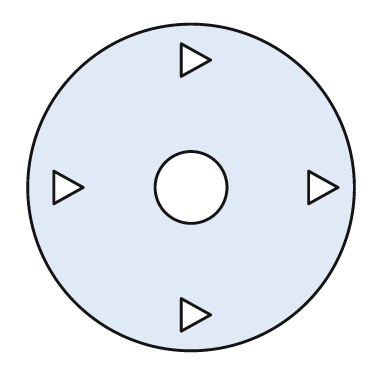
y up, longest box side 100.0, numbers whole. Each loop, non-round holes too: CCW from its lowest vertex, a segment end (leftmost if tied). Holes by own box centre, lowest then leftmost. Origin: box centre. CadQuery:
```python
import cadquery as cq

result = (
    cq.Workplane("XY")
    .moveTo(0.0, 0.0)
    .circle(50.0)
    .moveTo(-3.0, -44.0)
    .lineTo(6.0, -39.0)
    .lineTo(-3.0, -34.0)
    .close()
    .moveTo(-42.0, -5.0)
    .lineTo(-33.0, 0.0)
    .lineTo(-42.0, 5.0)
    .close()
    .moveTo(0.0, 0.0)
    .circle(11.0)
    .moveTo(36.0, -5.0)
    .lineTo(45.0, 0.0)
    .lineTo(36.0, 5.0)
    .close()
    .moveTo(-3.0, 34.0)
    .lineTo(6.0, 39.0)
    .lineTo(-3.0, 44.0)
    .close()
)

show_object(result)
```